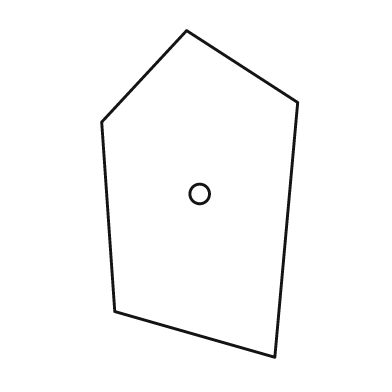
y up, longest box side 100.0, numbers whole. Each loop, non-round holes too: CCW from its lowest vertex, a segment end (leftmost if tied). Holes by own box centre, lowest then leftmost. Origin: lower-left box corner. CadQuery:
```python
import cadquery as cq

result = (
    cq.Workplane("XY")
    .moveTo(53.0, 0.0)
    .lineTo(60.0, 78.0)
    .lineTo(26.0, 100.0)
    .lineTo(0.0, 72.0)
    .lineTo(4.0, 14.0)
    .close()
    .moveTo(30.0, 50.0)
    .circle(3.0)
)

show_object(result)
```